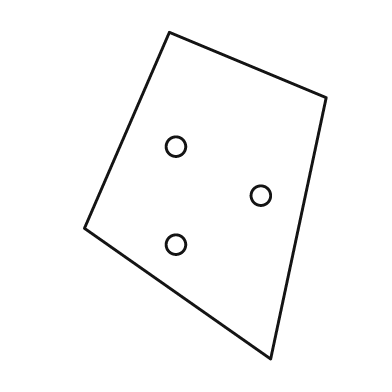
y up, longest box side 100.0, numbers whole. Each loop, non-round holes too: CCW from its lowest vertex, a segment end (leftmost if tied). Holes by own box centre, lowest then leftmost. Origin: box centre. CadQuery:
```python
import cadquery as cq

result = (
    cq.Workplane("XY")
    .moveTo(20.0, -50.0)
    .lineTo(37.0, 30.0)
    .lineTo(-11.0, 50.0)
    .lineTo(-37.0, -10.0)
    .close()
    .moveTo(-9.0, -15.0)
    .circle(3.0)
    .moveTo(17.0, 0.0)
    .circle(3.0)
    .moveTo(-9.0, 15.0)
    .circle(3.0)
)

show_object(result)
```